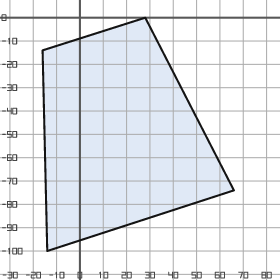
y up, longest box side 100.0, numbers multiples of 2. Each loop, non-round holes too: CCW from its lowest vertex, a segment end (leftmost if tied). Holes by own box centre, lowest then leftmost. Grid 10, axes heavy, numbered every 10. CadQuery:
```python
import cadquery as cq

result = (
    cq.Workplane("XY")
    .moveTo(-14.0, -100.0)
    .lineTo(66.0, -74.0)
    .lineTo(28.0, 0.0)
    .lineTo(-16.0, -14.0)
    .close()
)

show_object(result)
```